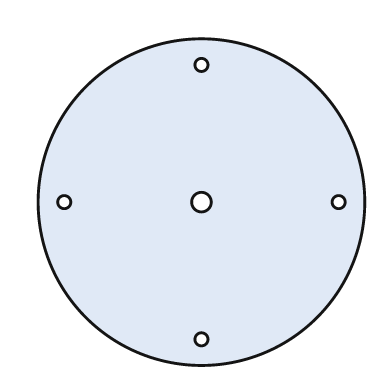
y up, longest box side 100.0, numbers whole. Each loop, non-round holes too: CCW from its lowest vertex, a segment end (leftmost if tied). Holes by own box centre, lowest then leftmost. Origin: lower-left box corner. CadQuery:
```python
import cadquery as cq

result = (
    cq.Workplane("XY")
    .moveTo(50.0, 50.0)
    .circle(50.0)
    .moveTo(50.0, 8.0)
    .circle(2.0)
    .moveTo(8.0, 50.0)
    .circle(2.0)
    .moveTo(50.0, 50.0)
    .circle(3.0)
    .moveTo(92.0, 50.0)
    .circle(2.0)
    .moveTo(50.0, 92.0)
    .circle(2.0)
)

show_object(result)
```